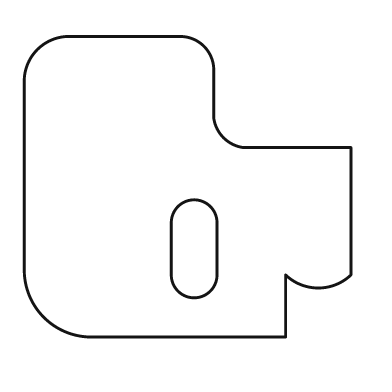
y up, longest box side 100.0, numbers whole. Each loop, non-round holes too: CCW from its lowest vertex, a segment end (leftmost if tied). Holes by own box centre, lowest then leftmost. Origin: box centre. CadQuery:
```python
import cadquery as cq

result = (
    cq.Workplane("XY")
    .moveTo(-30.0, -46.0)
    .lineTo(30.0, -46.0)
    .lineTo(30.0, -27.0)
    .threePointArc((40.0, -31.0), (50.0, -27.0))
    .lineTo(50.0, 12.0)
    .lineTo(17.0, 12.0)
    .threePointArc((11.0, 15.0), (8.0, 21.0))
    .lineTo(8.0, 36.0)
    .threePointArc((5.0, 43.0), (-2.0, 46.0))
    .lineTo(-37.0, 46.0)
    .threePointArc((-46.0, 42.0), (-50.0, 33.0))
    .lineTo(-50.0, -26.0)
    .threePointArc((-44.0, -40.0), (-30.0, -46.0))
    .close()
    .moveTo(-5.0, -27.0)
    .threePointArc((2.0, -34.0), (9.0, -27.0))
    .lineTo(9.0, -11.0)
    .threePointArc((2.0, -4.0), (-5.0, -11.0))
    .close()
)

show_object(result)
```